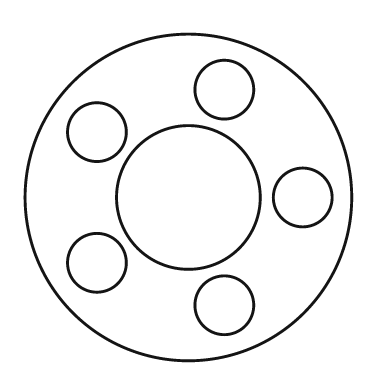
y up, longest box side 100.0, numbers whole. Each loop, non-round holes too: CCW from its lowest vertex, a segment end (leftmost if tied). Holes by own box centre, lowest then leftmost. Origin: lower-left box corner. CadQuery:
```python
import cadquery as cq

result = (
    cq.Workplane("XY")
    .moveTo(50.0, 50.0)
    .circle(50.0)
    .moveTo(61.0, 17.0)
    .circle(9.0)
    .moveTo(22.0, 30.0)
    .circle(9.0)
    .moveTo(50.0, 50.0)
    .circle(22.0)
    .moveTo(85.0, 50.0)
    .circle(9.0)
    .moveTo(22.0, 70.0)
    .circle(9.0)
    .moveTo(61.0, 83.0)
    .circle(9.0)
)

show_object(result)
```